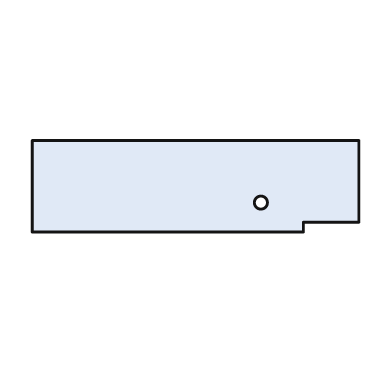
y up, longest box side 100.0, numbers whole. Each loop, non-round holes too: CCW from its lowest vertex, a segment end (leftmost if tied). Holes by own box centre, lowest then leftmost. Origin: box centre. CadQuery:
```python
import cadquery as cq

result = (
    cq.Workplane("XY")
    .moveTo(-50.0, -14.0)
    .lineTo(33.0, -14.0)
    .lineTo(33.0, -11.0)
    .lineTo(50.0, -11.0)
    .lineTo(50.0, 14.0)
    .lineTo(-50.0, 14.0)
    .close()
    .moveTo(20.0, -5.0)
    .circle(2.0)
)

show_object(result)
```